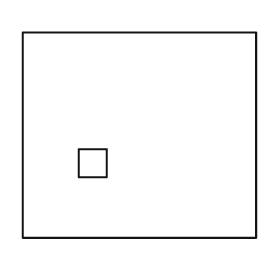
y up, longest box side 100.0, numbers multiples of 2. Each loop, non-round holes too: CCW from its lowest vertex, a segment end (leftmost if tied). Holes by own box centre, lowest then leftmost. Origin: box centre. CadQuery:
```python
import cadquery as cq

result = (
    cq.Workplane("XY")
    .moveTo(-50.0, -44.0)
    .lineTo(50.0, -44.0)
    .lineTo(50.0, 44.0)
    .lineTo(-50.0, 44.0)
    .close()
    .moveTo(-26.0, -18.0)
    .lineTo(-14.0, -18.0)
    .lineTo(-14.0, -6.0)
    .lineTo(-26.0, -6.0)
    .close()
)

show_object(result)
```